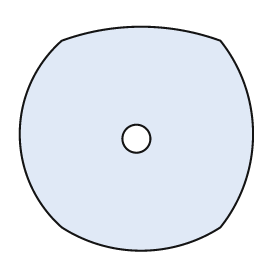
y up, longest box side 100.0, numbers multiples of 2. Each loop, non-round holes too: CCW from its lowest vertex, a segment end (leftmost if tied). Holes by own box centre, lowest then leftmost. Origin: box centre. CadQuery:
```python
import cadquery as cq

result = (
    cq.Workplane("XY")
    .moveTo(-32.0, -38.0)
    .threePointArc((2.0, -48.0), (36.0, -38.0))
    .threePointArc((50.0, 2.0), (36.0, 42.0))
    .threePointArc((2.0, 48.0), (-32.0, 42.0))
    .threePointArc((-50.0, 2.0), (-32.0, -38.0))
    .close()
    .moveTo(0.0, 0.0)
    .circle(6.0)
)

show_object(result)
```